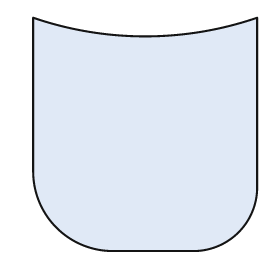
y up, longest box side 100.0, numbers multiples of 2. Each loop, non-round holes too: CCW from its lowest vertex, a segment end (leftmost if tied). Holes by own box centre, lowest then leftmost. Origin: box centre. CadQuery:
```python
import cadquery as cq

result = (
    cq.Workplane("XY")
    .moveTo(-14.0, -50.0)
    .lineTo(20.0, -50.0)
    .threePointArc((40.0, -42.0), (48.0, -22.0))
    .lineTo(48.0, 50.0)
    .threePointArc((0.0, 42.0), (-48.0, 50.0))
    .lineTo(-48.0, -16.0)
    .threePointArc((-38.0, -40.0), (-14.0, -50.0))
    .close()
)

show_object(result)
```